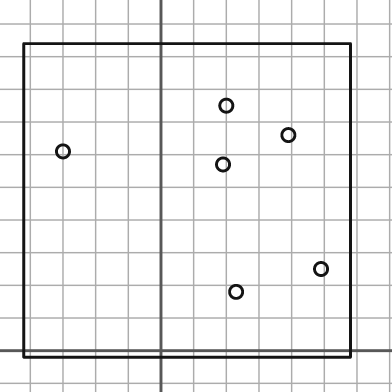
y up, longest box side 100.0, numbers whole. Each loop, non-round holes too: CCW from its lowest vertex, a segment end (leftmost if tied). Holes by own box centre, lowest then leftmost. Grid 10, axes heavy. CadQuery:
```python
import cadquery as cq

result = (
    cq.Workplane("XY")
    .moveTo(-42.0, -2.0)
    .lineTo(58.0, -2.0)
    .lineTo(58.0, 94.0)
    .lineTo(-42.0, 94.0)
    .close()
    .moveTo(23.0, 18.0)
    .circle(2.0)
    .moveTo(49.0, 25.0)
    .circle(2.0)
    .moveTo(19.0, 57.0)
    .circle(2.0)
    .moveTo(-30.0, 61.0)
    .circle(2.0)
    .moveTo(39.0, 66.0)
    .circle(2.0)
    .moveTo(20.0, 75.0)
    .circle(2.0)
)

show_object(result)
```